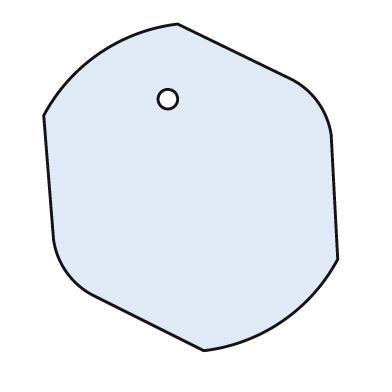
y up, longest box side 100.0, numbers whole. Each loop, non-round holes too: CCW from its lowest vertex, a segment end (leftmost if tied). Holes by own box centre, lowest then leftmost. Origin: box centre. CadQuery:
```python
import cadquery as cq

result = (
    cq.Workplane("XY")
    .moveTo(4.0, -50.0)
    .threePointArc((28.0, -41.0), (45.0, -22.0))
    .lineTo(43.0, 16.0)
    .threePointArc((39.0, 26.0), (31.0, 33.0))
    .lineTo(-4.0, 50.0)
    .threePointArc((-28.0, 41.0), (-45.0, 22.0))
    .lineTo(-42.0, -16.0)
    .threePointArc((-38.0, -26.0), (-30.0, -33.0))
    .close()
    .moveTo(-7.0, 27.0)
    .circle(3.0)
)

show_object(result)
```